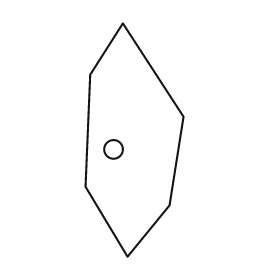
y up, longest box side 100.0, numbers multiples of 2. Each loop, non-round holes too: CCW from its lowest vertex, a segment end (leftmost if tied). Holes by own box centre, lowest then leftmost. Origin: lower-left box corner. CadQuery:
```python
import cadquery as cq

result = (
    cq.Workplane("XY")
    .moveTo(18.0, 0.0)
    .lineTo(36.0, 22.0)
    .lineTo(42.0, 60.0)
    .lineTo(16.0, 100.0)
    .lineTo(2.0, 78.0)
    .lineTo(0.0, 30.0)
    .close()
    .moveTo(12.0, 46.0)
    .circle(4.0)
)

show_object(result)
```